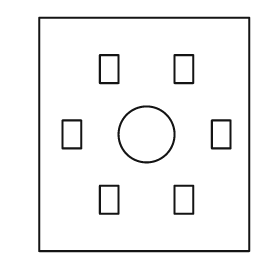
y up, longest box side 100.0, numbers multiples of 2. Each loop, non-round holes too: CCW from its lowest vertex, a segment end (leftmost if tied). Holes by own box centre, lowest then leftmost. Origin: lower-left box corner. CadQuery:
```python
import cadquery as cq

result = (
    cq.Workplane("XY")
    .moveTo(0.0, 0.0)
    .lineTo(90.0, 0.0)
    .lineTo(90.0, 100.0)
    .lineTo(0.0, 100.0)
    .close()
    .moveTo(26.0, 16.0)
    .lineTo(34.0, 16.0)
    .lineTo(34.0, 28.0)
    .lineTo(26.0, 28.0)
    .close()
    .moveTo(58.0, 16.0)
    .lineTo(66.0, 16.0)
    .lineTo(66.0, 28.0)
    .lineTo(58.0, 28.0)
    .close()
    .moveTo(10.0, 44.0)
    .lineTo(18.0, 44.0)
    .lineTo(18.0, 56.0)
    .lineTo(10.0, 56.0)
    .close()
    .moveTo(46.0, 50.0)
    .circle(12.0)
    .moveTo(74.0, 44.0)
    .lineTo(82.0, 44.0)
    .lineTo(82.0, 56.0)
    .lineTo(74.0, 56.0)
    .close()
    .moveTo(26.0, 72.0)
    .lineTo(34.0, 72.0)
    .lineTo(34.0, 84.0)
    .lineTo(26.0, 84.0)
    .close()
    .moveTo(58.0, 72.0)
    .lineTo(66.0, 72.0)
    .lineTo(66.0, 84.0)
    .lineTo(58.0, 84.0)
    .close()
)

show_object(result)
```